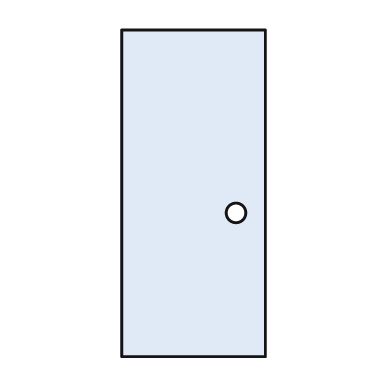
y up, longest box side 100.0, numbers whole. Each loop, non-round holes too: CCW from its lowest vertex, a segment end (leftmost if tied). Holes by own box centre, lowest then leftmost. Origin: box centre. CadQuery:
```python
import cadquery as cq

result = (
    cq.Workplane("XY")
    .moveTo(-22.0, -50.0)
    .lineTo(22.0, -50.0)
    .lineTo(22.0, 50.0)
    .lineTo(-22.0, 50.0)
    .close()
    .moveTo(13.0, -6.0)
    .circle(3.0)
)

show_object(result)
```